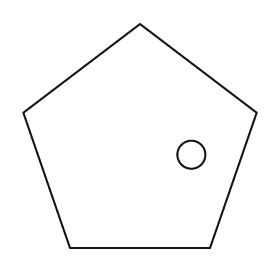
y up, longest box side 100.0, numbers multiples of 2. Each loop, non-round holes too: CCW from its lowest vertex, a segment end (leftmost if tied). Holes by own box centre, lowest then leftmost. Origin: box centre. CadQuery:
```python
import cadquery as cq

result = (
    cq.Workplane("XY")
    .moveTo(-30.0, -48.0)
    .lineTo(30.0, -48.0)
    .lineTo(50.0, 10.0)
    .lineTo(0.0, 48.0)
    .lineTo(-50.0, 10.0)
    .close()
    .moveTo(22.0, -8.0)
    .circle(6.0)
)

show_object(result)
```